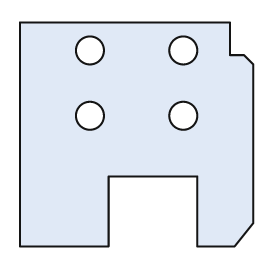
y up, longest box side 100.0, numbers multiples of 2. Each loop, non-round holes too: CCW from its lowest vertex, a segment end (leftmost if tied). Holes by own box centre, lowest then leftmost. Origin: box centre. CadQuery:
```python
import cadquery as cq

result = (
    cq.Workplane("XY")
    .moveTo(-50.0, -48.0)
    .lineTo(-12.0, -48.0)
    .lineTo(-12.0, -18.0)
    .lineTo(26.0, -18.0)
    .lineTo(26.0, -48.0)
    .lineTo(42.0, -48.0)
    .lineTo(50.0, -38.0)
    .lineTo(50.0, 30.0)
    .lineTo(46.0, 34.0)
    .lineTo(40.0, 34.0)
    .lineTo(40.0, 48.0)
    .lineTo(-50.0, 48.0)
    .close()
    .moveTo(-20.0, 8.0)
    .circle(6.0)
    .moveTo(20.0, 8.0)
    .circle(6.0)
    .moveTo(-20.0, 36.0)
    .circle(6.0)
    .moveTo(20.0, 36.0)
    .circle(6.0)
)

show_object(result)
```